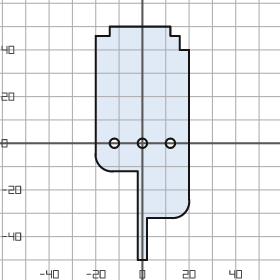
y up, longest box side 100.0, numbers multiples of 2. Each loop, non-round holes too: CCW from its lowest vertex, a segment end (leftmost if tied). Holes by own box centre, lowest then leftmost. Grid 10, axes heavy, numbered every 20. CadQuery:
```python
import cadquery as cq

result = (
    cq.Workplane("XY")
    .moveTo(-2.0, -50.0)
    .lineTo(2.0, -50.0)
    .lineTo(2.0, -32.0)
    .lineTo(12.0, -32.0)
    .threePointArc((18.0, -30.0), (20.0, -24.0))
    .lineTo(20.0, 40.0)
    .lineTo(16.0, 40.0)
    .lineTo(16.0, 46.0)
    .lineTo(12.0, 46.0)
    .lineTo(12.0, 50.0)
    .lineTo(-14.0, 50.0)
    .lineTo(-14.0, 46.0)
    .lineTo(-20.0, 46.0)
    .lineTo(-20.0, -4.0)
    .threePointArc((-18.0, -10.0), (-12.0, -12.0))
    .lineTo(-2.0, -12.0)
    .close()
    .moveTo(-12.0, 0.0)
    .circle(2.0)
    .moveTo(0.0, 0.0)
    .circle(2.0)
    .moveTo(12.0, 0.0)
    .circle(2.0)
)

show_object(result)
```